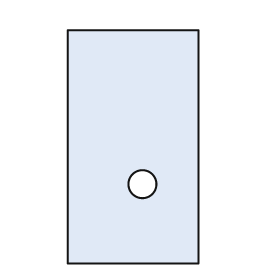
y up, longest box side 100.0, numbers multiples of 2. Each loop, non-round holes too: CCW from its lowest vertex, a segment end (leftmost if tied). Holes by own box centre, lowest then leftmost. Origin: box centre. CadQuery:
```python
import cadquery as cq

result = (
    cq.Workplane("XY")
    .moveTo(-28.0, -50.0)
    .lineTo(28.0, -50.0)
    .lineTo(28.0, 50.0)
    .lineTo(-28.0, 50.0)
    .close()
    .moveTo(4.0, -16.0)
    .circle(6.0)
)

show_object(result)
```